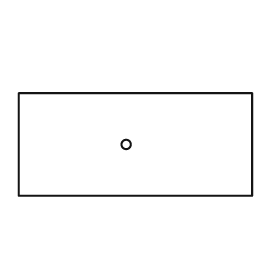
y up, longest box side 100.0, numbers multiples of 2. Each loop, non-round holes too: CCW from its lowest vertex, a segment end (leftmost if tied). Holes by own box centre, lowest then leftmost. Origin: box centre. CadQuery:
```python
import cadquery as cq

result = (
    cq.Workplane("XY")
    .moveTo(-50.0, -22.0)
    .lineTo(50.0, -22.0)
    .lineTo(50.0, 22.0)
    .lineTo(-50.0, 22.0)
    .close()
    .moveTo(-4.0, 0.0)
    .circle(2.0)
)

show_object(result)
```